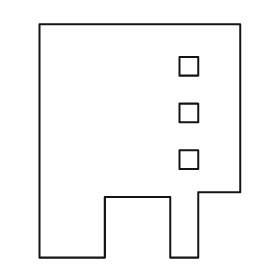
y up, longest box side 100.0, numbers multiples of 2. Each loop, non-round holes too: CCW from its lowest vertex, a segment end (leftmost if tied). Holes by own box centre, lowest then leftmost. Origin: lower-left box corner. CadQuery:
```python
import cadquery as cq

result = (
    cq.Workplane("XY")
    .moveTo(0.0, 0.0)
    .lineTo(28.0, 0.0)
    .lineTo(28.0, 26.0)
    .lineTo(56.0, 26.0)
    .lineTo(56.0, 0.0)
    .lineTo(68.0, 0.0)
    .lineTo(68.0, 28.0)
    .lineTo(86.0, 28.0)
    .lineTo(86.0, 100.0)
    .lineTo(0.0, 100.0)
    .close()
    .moveTo(60.0, 38.0)
    .lineTo(68.0, 38.0)
    .lineTo(68.0, 46.0)
    .lineTo(60.0, 46.0)
    .close()
    .moveTo(60.0, 58.0)
    .lineTo(68.0, 58.0)
    .lineTo(68.0, 66.0)
    .lineTo(60.0, 66.0)
    .close()
    .moveTo(60.0, 78.0)
    .lineTo(68.0, 78.0)
    .lineTo(68.0, 86.0)
    .lineTo(60.0, 86.0)
    .close()
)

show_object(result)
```